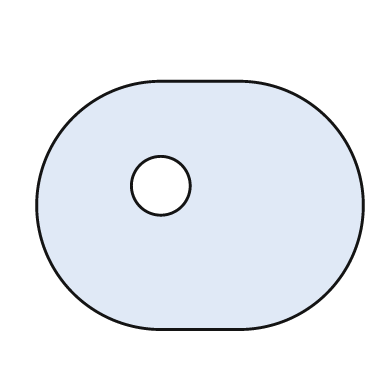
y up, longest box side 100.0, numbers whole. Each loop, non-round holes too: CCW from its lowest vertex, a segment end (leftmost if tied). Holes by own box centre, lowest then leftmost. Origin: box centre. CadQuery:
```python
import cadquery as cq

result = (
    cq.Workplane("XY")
    .moveTo(-12.0, -38.0)
    .lineTo(12.0, -38.0)
    .threePointArc((50.0, 0.0), (12.0, 38.0))
    .lineTo(-12.0, 38.0)
    .threePointArc((-50.0, 0.0), (-12.0, -38.0))
    .close()
    .moveTo(-12.0, 6.0)
    .circle(9.0)
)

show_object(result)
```